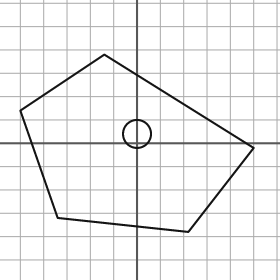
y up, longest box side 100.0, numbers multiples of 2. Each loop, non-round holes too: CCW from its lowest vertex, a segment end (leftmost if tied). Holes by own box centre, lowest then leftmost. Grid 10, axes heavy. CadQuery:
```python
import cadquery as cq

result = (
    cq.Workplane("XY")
    .moveTo(22.0, -38.0)
    .lineTo(50.0, -2.0)
    .lineTo(-14.0, 38.0)
    .lineTo(-50.0, 14.0)
    .lineTo(-34.0, -32.0)
    .close()
    .moveTo(0.0, 4.0)
    .circle(6.0)
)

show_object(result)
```